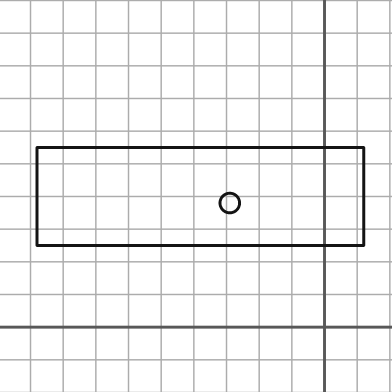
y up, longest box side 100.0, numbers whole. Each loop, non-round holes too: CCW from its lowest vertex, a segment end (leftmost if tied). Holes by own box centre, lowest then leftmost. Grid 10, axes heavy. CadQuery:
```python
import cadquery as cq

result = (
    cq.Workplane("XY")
    .moveTo(-88.0, 25.0)
    .lineTo(12.0, 25.0)
    .lineTo(12.0, 55.0)
    .lineTo(-88.0, 55.0)
    .close()
    .moveTo(-29.0, 38.0)
    .circle(3.0)
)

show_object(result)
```